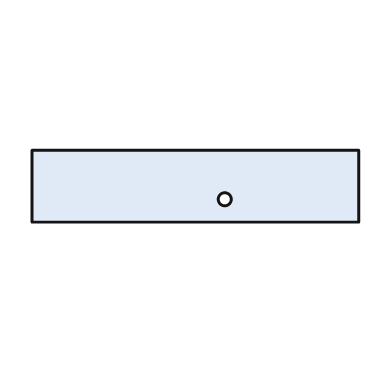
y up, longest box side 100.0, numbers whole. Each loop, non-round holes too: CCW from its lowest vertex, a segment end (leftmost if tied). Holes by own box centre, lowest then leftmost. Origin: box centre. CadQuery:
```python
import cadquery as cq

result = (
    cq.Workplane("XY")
    .moveTo(-50.0, -11.0)
    .lineTo(50.0, -11.0)
    .lineTo(50.0, 11.0)
    .lineTo(-50.0, 11.0)
    .close()
    .moveTo(9.0, -4.0)
    .circle(2.0)
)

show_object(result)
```